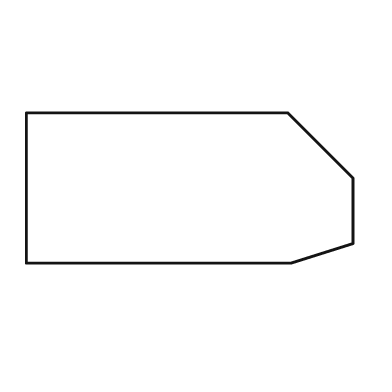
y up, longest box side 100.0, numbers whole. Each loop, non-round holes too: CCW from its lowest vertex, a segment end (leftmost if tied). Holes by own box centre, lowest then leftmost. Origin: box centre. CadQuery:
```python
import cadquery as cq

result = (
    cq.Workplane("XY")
    .moveTo(-50.0, -23.0)
    .lineTo(31.0, -23.0)
    .lineTo(50.0, -17.0)
    .lineTo(50.0, 3.0)
    .lineTo(30.0, 23.0)
    .lineTo(-50.0, 23.0)
    .close()
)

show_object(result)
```